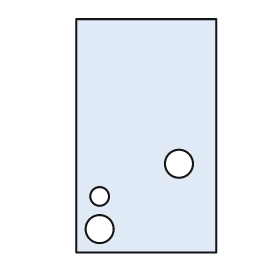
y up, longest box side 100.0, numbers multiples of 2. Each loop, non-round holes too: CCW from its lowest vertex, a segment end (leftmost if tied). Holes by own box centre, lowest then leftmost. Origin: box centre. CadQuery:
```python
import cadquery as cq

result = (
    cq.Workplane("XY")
    .moveTo(-30.0, -50.0)
    .lineTo(30.0, -50.0)
    .lineTo(30.0, 50.0)
    .lineTo(-30.0, 50.0)
    .close()
    .moveTo(-20.0, -40.0)
    .circle(6.0)
    .moveTo(-20.0, -26.0)
    .circle(4.0)
    .moveTo(14.0, -12.0)
    .circle(6.0)
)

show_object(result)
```